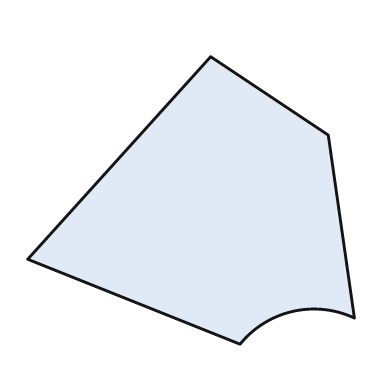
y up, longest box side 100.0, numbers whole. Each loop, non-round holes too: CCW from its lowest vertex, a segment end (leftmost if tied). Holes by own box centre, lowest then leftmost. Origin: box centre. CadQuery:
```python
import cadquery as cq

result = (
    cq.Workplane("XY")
    .moveTo(15.0, -44.0)
    .threePointArc((31.0, -34.0), (50.0, -36.0))
    .lineTo(42.0, 20.0)
    .lineTo(6.0, 44.0)
    .lineTo(-50.0, -18.0)
    .close()
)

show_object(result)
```